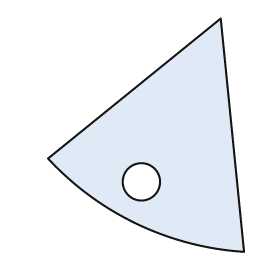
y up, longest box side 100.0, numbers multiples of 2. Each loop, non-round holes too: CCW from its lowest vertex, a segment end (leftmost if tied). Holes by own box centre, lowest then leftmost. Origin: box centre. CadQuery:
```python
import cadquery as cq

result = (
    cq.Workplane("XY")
    .moveTo(42.0, -50.0)
    .lineTo(32.0, 50.0)
    .lineTo(-42.0, -10.0)
    .threePointArc((-4.0, -38.0), (42.0, -50.0))
    .close()
    .moveTo(-2.0, -20.0)
    .circle(8.0)
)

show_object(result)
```